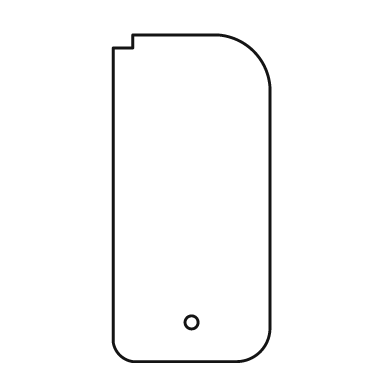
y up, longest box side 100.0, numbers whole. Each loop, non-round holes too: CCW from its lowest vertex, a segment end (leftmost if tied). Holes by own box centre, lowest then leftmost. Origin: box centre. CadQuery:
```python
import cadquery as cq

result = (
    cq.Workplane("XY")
    .moveTo(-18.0, -50.0)
    .lineTo(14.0, -50.0)
    .threePointArc((21.0, -47.0), (24.0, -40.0))
    .lineTo(24.0, 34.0)
    .threePointArc((19.0, 45.0), (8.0, 50.0))
    .lineTo(-18.0, 50.0)
    .lineTo(-18.0, 46.0)
    .lineTo(-24.0, 46.0)
    .lineTo(-24.0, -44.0)
    .threePointArc((-22.0, -48.0), (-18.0, -50.0))
    .close()
    .moveTo(0.0, -38.0)
    .circle(2.0)
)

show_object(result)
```